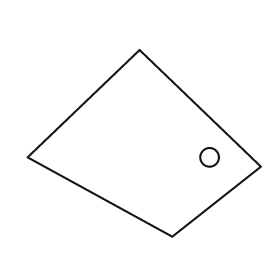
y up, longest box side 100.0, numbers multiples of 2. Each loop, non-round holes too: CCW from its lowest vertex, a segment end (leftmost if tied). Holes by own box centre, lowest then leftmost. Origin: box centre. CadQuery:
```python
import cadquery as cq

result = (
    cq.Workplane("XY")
    .moveTo(12.0, -40.0)
    .lineTo(50.0, -10.0)
    .lineTo(-2.0, 40.0)
    .lineTo(-50.0, -6.0)
    .close()
    .moveTo(28.0, -6.0)
    .circle(4.0)
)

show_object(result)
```